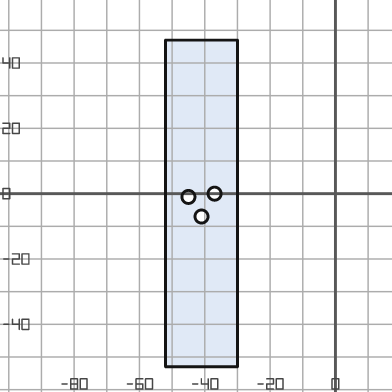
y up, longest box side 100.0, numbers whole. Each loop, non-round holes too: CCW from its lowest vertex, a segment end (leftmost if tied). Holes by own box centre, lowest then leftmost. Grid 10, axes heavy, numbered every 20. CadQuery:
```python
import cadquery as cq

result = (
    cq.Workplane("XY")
    .moveTo(-52.0, -53.0)
    .lineTo(-30.0, -53.0)
    .lineTo(-30.0, 47.0)
    .lineTo(-52.0, 47.0)
    .close()
    .moveTo(-41.0, -7.0)
    .circle(2.0)
    .moveTo(-45.0, -1.0)
    .circle(2.0)
    .moveTo(-37.0, 0.0)
    .circle(2.0)
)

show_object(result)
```